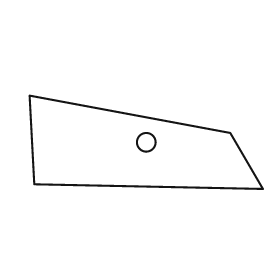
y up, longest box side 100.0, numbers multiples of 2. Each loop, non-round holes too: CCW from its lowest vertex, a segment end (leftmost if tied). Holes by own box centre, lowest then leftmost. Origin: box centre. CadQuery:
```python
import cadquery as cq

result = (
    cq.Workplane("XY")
    .moveTo(50.0, -20.0)
    .lineTo(36.0, 4.0)
    .lineTo(-50.0, 20.0)
    .lineTo(-48.0, -18.0)
    .close()
    .moveTo(0.0, 0.0)
    .circle(4.0)
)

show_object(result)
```